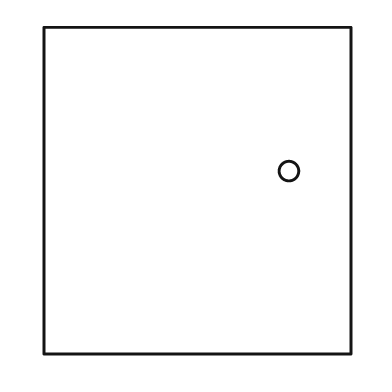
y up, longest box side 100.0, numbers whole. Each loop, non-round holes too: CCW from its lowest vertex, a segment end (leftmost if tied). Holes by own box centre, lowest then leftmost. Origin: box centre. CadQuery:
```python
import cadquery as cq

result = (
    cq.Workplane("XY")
    .moveTo(-47.0, -50.0)
    .lineTo(47.0, -50.0)
    .lineTo(47.0, 50.0)
    .lineTo(-47.0, 50.0)
    .close()
    .moveTo(28.0, 6.0)
    .circle(3.0)
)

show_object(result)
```